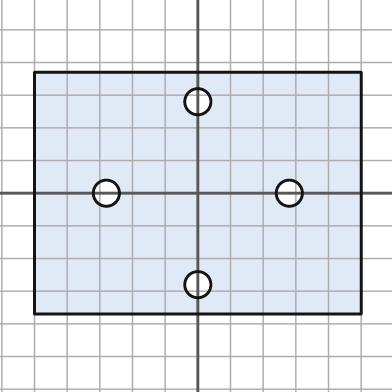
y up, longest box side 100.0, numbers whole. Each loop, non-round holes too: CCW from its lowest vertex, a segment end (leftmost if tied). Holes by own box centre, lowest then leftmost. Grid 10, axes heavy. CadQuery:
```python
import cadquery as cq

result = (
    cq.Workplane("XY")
    .moveTo(-50.0, -37.0)
    .lineTo(50.0, -37.0)
    .lineTo(50.0, 37.0)
    .lineTo(-50.0, 37.0)
    .close()
    .moveTo(0.0, -28.0)
    .circle(4.0)
    .moveTo(-28.0, 0.0)
    .circle(4.0)
    .moveTo(28.0, 0.0)
    .circle(4.0)
    .moveTo(0.0, 28.0)
    .circle(4.0)
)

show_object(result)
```